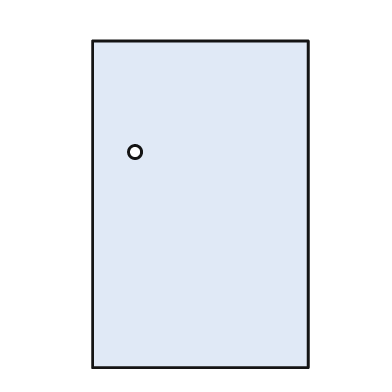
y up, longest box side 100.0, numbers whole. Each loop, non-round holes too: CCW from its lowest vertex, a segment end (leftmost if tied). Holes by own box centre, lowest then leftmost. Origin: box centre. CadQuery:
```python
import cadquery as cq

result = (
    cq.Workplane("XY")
    .moveTo(-33.0, -50.0)
    .lineTo(33.0, -50.0)
    .lineTo(33.0, 50.0)
    .lineTo(-33.0, 50.0)
    .close()
    .moveTo(-20.0, 16.0)
    .circle(2.0)
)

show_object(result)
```